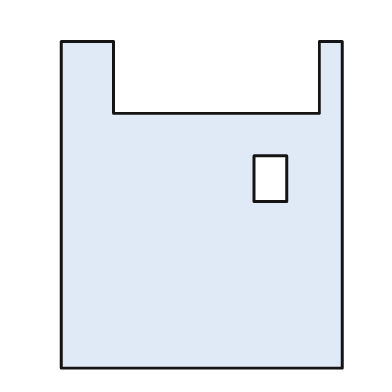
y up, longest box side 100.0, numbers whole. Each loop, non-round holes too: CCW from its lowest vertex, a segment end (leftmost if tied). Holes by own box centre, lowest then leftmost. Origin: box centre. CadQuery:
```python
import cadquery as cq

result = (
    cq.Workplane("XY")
    .moveTo(-43.0, -50.0)
    .lineTo(43.0, -50.0)
    .lineTo(43.0, 50.0)
    .lineTo(36.0, 50.0)
    .lineTo(36.0, 28.0)
    .lineTo(-27.0, 28.0)
    .lineTo(-27.0, 50.0)
    .lineTo(-43.0, 50.0)
    .close()
    .moveTo(16.0, 1.0)
    .lineTo(26.0, 1.0)
    .lineTo(26.0, 15.0)
    .lineTo(16.0, 15.0)
    .close()
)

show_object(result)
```